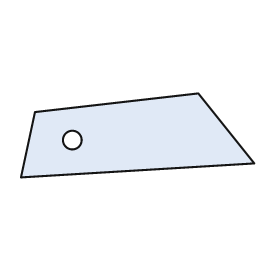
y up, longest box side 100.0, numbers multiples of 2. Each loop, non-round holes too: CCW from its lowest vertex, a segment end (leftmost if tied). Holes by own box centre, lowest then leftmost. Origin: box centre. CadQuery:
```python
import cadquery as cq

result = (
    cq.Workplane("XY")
    .moveTo(-50.0, -18.0)
    .lineTo(50.0, -12.0)
    .lineTo(26.0, 18.0)
    .lineTo(-44.0, 10.0)
    .close()
    .moveTo(-28.0, -2.0)
    .circle(4.0)
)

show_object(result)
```